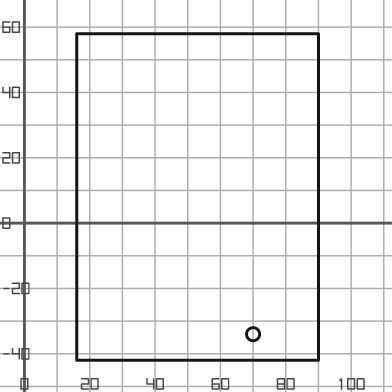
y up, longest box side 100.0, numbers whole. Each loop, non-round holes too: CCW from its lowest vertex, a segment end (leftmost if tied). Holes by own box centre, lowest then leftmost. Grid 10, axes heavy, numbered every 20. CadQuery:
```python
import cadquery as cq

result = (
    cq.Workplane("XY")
    .moveTo(16.0, -42.0)
    .lineTo(90.0, -42.0)
    .lineTo(90.0, 58.0)
    .lineTo(16.0, 58.0)
    .close()
    .moveTo(70.0, -34.0)
    .circle(2.0)
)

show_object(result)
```